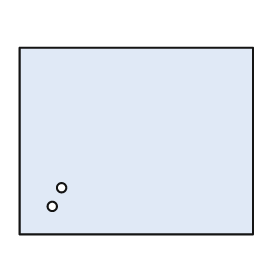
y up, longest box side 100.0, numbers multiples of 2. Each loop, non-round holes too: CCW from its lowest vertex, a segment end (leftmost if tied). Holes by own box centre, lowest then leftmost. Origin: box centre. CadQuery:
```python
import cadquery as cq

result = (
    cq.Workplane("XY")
    .moveTo(-50.0, -40.0)
    .lineTo(50.0, -40.0)
    .lineTo(50.0, 40.0)
    .lineTo(-50.0, 40.0)
    .close()
    .moveTo(-36.0, -28.0)
    .circle(2.0)
    .moveTo(-32.0, -20.0)
    .circle(2.0)
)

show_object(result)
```